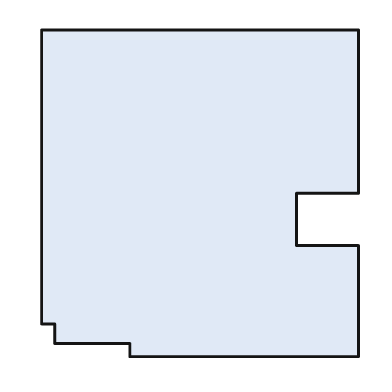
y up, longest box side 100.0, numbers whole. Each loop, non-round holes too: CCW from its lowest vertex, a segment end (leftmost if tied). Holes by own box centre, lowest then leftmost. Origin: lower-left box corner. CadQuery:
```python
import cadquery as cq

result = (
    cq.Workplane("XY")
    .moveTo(27.0, 0.0)
    .lineTo(97.0, 0.0)
    .lineTo(97.0, 34.0)
    .lineTo(78.0, 34.0)
    .lineTo(78.0, 50.0)
    .lineTo(97.0, 50.0)
    .lineTo(97.0, 100.0)
    .lineTo(0.0, 100.0)
    .lineTo(0.0, 10.0)
    .lineTo(4.0, 10.0)
    .lineTo(4.0, 4.0)
    .lineTo(27.0, 4.0)
    .close()
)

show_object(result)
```